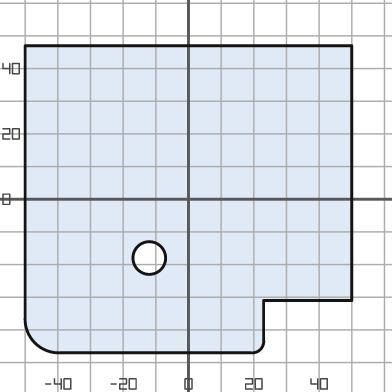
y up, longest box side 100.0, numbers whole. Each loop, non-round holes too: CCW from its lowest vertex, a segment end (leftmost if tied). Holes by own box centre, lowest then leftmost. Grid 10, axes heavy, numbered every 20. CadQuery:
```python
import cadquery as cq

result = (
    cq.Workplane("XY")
    .moveTo(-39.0, -47.0)
    .lineTo(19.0, -47.0)
    .threePointArc((22.0, -46.0), (23.0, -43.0))
    .lineTo(23.0, -31.0)
    .lineTo(50.0, -31.0)
    .lineTo(50.0, 47.0)
    .lineTo(-50.0, 47.0)
    .lineTo(-50.0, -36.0)
    .threePointArc((-47.0, -44.0), (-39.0, -47.0))
    .close()
    .moveTo(-12.0, -18.0)
    .circle(5.0)
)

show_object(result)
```